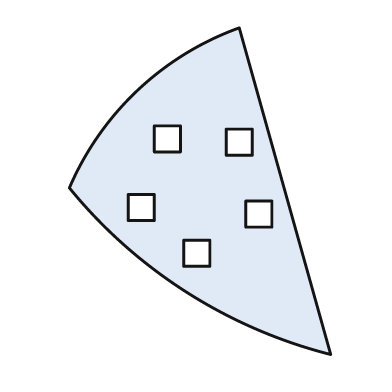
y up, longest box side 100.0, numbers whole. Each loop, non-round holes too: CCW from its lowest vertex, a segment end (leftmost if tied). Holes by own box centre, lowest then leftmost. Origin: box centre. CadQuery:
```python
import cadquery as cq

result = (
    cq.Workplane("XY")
    .moveTo(40.0, -50.0)
    .lineTo(12.0, 50.0)
    .threePointArc((-19.0, 31.0), (-40.0, 1.0))
    .threePointArc((-4.0, -31.0), (40.0, -50.0))
    .close()
    .moveTo(-5.0, -23.0)
    .lineTo(3.0, -23.0)
    .lineTo(3.0, -15.0)
    .lineTo(-5.0, -15.0)
    .close()
    .moveTo(14.0, -11.0)
    .lineTo(22.0, -11.0)
    .lineTo(22.0, -3.0)
    .lineTo(14.0, -3.0)
    .close()
    .moveTo(-22.0, -9.0)
    .lineTo(-14.0, -9.0)
    .lineTo(-14.0, -1.0)
    .lineTo(-22.0, -1.0)
    .close()
    .moveTo(8.0, 11.0)
    .lineTo(16.0, 11.0)
    .lineTo(16.0, 19.0)
    .lineTo(8.0, 19.0)
    .close()
    .moveTo(-14.0, 12.0)
    .lineTo(-6.0, 12.0)
    .lineTo(-6.0, 20.0)
    .lineTo(-14.0, 20.0)
    .close()
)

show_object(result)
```